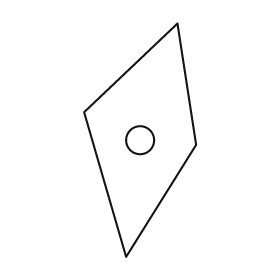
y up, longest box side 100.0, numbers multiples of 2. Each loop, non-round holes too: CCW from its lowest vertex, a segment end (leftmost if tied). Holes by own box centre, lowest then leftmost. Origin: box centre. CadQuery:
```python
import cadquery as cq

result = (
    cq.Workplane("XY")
    .moveTo(-6.0, -50.0)
    .lineTo(24.0, -2.0)
    .lineTo(16.0, 50.0)
    .lineTo(-24.0, 12.0)
    .close()
    .moveTo(0.0, 0.0)
    .circle(6.0)
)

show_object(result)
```